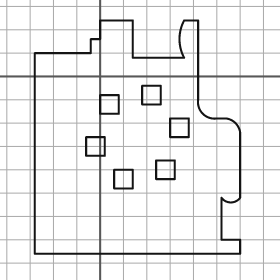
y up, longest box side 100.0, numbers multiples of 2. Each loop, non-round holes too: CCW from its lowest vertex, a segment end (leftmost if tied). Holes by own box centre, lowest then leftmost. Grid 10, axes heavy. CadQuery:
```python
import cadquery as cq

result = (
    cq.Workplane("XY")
    .moveTo(-28.0, -76.0)
    .lineTo(60.0, -76.0)
    .lineTo(60.0, -70.0)
    .lineTo(52.0, -70.0)
    .lineTo(52.0, -52.0)
    .threePointArc((56.0, -54.0), (60.0, -52.0))
    .lineTo(60.0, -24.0)
    .threePointArc((58.0, -20.0), (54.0, -18.0))
    .lineTo(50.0, -18.0)
    .threePointArc((44.0, -16.0), (42.0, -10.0))
    .lineTo(42.0, 24.0)
    .lineTo(36.0, 24.0)
    .threePointArc((34.0, 16.0), (36.0, 8.0))
    .lineTo(14.0, 8.0)
    .lineTo(14.0, 24.0)
    .lineTo(0.0, 24.0)
    .lineTo(0.0, 16.0)
    .lineTo(-4.0, 16.0)
    .lineTo(-4.0, 10.0)
    .lineTo(-28.0, 10.0)
    .close()
    .moveTo(6.0, -48.0)
    .lineTo(14.0, -48.0)
    .lineTo(14.0, -40.0)
    .lineTo(6.0, -40.0)
    .close()
    .moveTo(24.0, -44.0)
    .lineTo(32.0, -44.0)
    .lineTo(32.0, -36.0)
    .lineTo(24.0, -36.0)
    .close()
    .moveTo(-6.0, -34.0)
    .lineTo(2.0, -34.0)
    .lineTo(2.0, -26.0)
    .lineTo(-6.0, -26.0)
    .close()
    .moveTo(30.0, -26.0)
    .lineTo(38.0, -26.0)
    .lineTo(38.0, -18.0)
    .lineTo(30.0, -18.0)
    .close()
    .moveTo(0.0, -16.0)
    .lineTo(8.0, -16.0)
    .lineTo(8.0, -8.0)
    .lineTo(0.0, -8.0)
    .close()
    .moveTo(18.0, -12.0)
    .lineTo(26.0, -12.0)
    .lineTo(26.0, -4.0)
    .lineTo(18.0, -4.0)
    .close()
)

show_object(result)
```